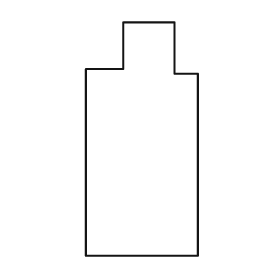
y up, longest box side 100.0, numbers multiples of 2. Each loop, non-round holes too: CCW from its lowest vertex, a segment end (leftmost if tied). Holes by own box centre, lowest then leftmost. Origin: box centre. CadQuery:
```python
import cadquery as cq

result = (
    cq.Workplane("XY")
    .moveTo(-24.0, -50.0)
    .lineTo(24.0, -50.0)
    .lineTo(24.0, 28.0)
    .lineTo(14.0, 28.0)
    .lineTo(14.0, 50.0)
    .lineTo(-8.0, 50.0)
    .lineTo(-8.0, 30.0)
    .lineTo(-24.0, 30.0)
    .close()
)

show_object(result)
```